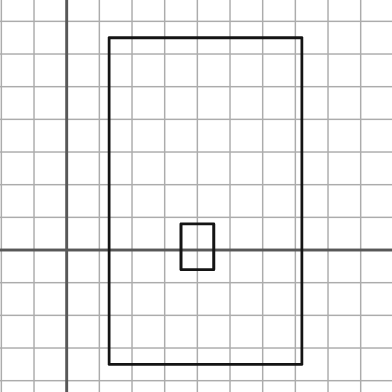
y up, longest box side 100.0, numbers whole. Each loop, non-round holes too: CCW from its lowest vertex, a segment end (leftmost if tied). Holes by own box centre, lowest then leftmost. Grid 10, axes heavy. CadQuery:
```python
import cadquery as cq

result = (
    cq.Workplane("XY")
    .moveTo(13.0, -35.0)
    .lineTo(72.0, -35.0)
    .lineTo(72.0, 65.0)
    .lineTo(13.0, 65.0)
    .close()
    .moveTo(35.0, -6.0)
    .lineTo(45.0, -6.0)
    .lineTo(45.0, 8.0)
    .lineTo(35.0, 8.0)
    .close()
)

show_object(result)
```